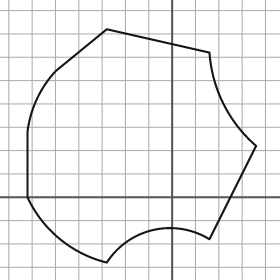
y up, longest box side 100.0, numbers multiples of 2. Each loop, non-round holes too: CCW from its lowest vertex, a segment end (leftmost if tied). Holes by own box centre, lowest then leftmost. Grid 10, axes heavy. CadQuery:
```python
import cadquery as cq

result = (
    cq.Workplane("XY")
    .moveTo(-28.0, -28.0)
    .threePointArc((-8.0, -14.0), (16.0, -18.0))
    .lineTo(36.0, 22.0)
    .threePointArc((22.0, 40.0), (16.0, 62.0))
    .lineTo(-28.0, 72.0)
    .lineTo(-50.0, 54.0)
    .threePointArc((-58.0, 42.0), (-62.0, 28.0))
    .lineTo(-62.0, 0.0)
    .threePointArc((-48.0, -18.0), (-28.0, -28.0))
    .close()
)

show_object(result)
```